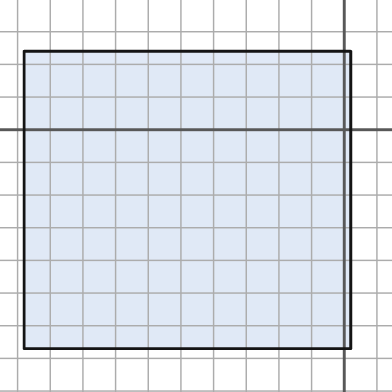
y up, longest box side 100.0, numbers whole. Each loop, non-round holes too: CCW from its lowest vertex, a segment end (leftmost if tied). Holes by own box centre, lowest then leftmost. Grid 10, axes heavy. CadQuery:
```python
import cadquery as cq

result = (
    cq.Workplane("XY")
    .moveTo(-98.0, -67.0)
    .lineTo(2.0, -67.0)
    .lineTo(2.0, 24.0)
    .lineTo(-98.0, 24.0)
    .close()
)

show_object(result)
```